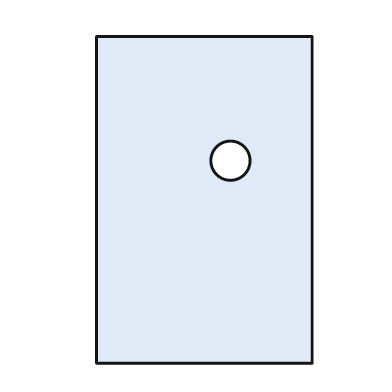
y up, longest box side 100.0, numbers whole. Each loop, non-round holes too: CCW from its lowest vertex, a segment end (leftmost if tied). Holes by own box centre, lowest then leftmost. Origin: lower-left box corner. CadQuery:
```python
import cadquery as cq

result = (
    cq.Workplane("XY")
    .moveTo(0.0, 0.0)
    .lineTo(66.0, 0.0)
    .lineTo(66.0, 100.0)
    .lineTo(0.0, 100.0)
    .close()
    .moveTo(41.0, 62.0)
    .circle(6.0)
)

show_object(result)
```